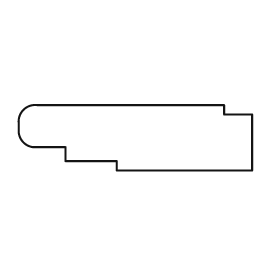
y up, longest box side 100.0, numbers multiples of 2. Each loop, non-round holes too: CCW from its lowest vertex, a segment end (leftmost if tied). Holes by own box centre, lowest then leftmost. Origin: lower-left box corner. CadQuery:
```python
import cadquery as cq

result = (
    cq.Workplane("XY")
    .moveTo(42.0, 0.0)
    .lineTo(100.0, 0.0)
    .lineTo(100.0, 24.0)
    .lineTo(88.0, 24.0)
    .lineTo(88.0, 28.0)
    .lineTo(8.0, 28.0)
    .threePointArc((2.0, 26.0), (0.0, 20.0))
    .lineTo(0.0, 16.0)
    .threePointArc((2.0, 12.0), (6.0, 10.0))
    .lineTo(20.0, 10.0)
    .lineTo(20.0, 4.0)
    .lineTo(42.0, 4.0)
    .close()
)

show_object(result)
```